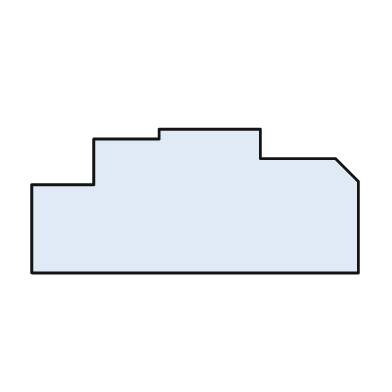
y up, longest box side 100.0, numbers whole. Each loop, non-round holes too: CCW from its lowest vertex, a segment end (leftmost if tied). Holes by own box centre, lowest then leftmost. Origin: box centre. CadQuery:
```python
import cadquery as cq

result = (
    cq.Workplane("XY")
    .moveTo(-50.0, -22.0)
    .lineTo(50.0, -22.0)
    .lineTo(50.0, 6.0)
    .lineTo(43.0, 13.0)
    .lineTo(20.0, 13.0)
    .lineTo(20.0, 22.0)
    .lineTo(-11.0, 22.0)
    .lineTo(-11.0, 19.0)
    .lineTo(-31.0, 19.0)
    .lineTo(-31.0, 5.0)
    .lineTo(-50.0, 5.0)
    .close()
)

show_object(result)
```